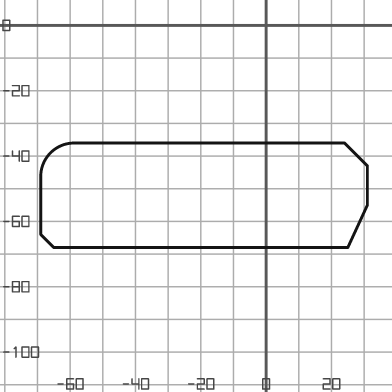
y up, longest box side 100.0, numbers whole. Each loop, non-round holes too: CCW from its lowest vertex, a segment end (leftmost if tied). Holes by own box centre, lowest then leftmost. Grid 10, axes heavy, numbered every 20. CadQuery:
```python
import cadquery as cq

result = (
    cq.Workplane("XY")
    .moveTo(-65.0, -68.0)
    .lineTo(25.0, -68.0)
    .lineTo(31.0, -55.0)
    .lineTo(31.0, -43.0)
    .lineTo(24.0, -36.0)
    .lineTo(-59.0, -36.0)
    .threePointArc((-66.0, -39.0), (-69.0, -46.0))
    .lineTo(-69.0, -64.0)
    .close()
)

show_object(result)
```